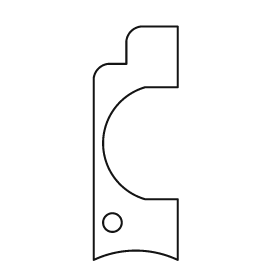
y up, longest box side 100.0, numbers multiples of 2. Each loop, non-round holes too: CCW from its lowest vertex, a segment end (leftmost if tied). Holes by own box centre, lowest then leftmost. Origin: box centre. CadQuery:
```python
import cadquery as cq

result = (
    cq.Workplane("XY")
    .moveTo(-18.0, -50.0)
    .threePointArc((0.0, -46.0), (18.0, -50.0))
    .lineTo(18.0, -24.0)
    .lineTo(4.0, -24.0)
    .threePointArc((-14.0, 0.0), (4.0, 24.0))
    .lineTo(18.0, 24.0)
    .lineTo(18.0, 50.0)
    .lineTo(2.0, 50.0)
    .threePointArc((-2.0, 48.0), (-4.0, 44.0))
    .lineTo(-4.0, 34.0)
    .lineTo(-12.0, 34.0)
    .threePointArc((-16.0, 32.0), (-18.0, 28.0))
    .close()
    .moveTo(-10.0, -34.0)
    .circle(4.0)
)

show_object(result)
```